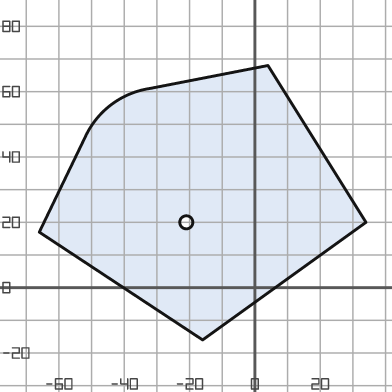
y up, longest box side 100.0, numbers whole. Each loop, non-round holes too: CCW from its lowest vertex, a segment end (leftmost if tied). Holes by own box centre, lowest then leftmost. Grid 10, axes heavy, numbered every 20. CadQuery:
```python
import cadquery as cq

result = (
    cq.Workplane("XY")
    .moveTo(-16.0, -16.0)
    .lineTo(34.0, 20.0)
    .lineTo(4.0, 68.0)
    .lineTo(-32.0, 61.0)
    .threePointArc((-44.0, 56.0), (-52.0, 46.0))
    .lineTo(-66.0, 17.0)
    .close()
    .moveTo(-21.0, 20.0)
    .circle(2.0)
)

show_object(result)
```